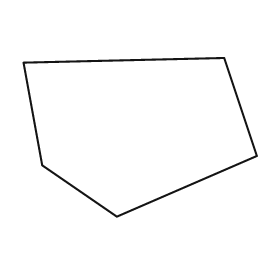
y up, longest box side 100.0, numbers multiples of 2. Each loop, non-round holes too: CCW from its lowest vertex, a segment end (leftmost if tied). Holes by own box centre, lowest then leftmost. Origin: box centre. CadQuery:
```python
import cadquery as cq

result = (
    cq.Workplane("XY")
    .moveTo(-10.0, -34.0)
    .lineTo(50.0, -8.0)
    .lineTo(36.0, 34.0)
    .lineTo(-50.0, 32.0)
    .lineTo(-42.0, -12.0)
    .close()
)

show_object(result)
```